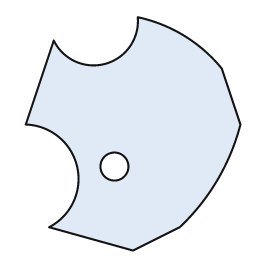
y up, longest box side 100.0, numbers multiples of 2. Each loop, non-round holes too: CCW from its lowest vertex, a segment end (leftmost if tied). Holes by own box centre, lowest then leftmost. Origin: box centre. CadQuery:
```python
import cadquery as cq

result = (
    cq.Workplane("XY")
    .moveTo(0.0, -50.0)
    .lineTo(20.0, -40.0)
    .threePointArc((36.0, -20.0), (46.0, 4.0))
    .lineTo(38.0, 28.0)
    .threePointArc((22.0, 42.0), (2.0, 50.0))
    .threePointArc((-12.0, 30.0), (-34.0, 40.0))
    .lineTo(-46.0, 4.0)
    .threePointArc((-24.0, -14.0), (-36.0, -40.0))
    .close()
    .moveTo(-8.0, -14.0)
    .circle(6.0)
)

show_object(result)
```